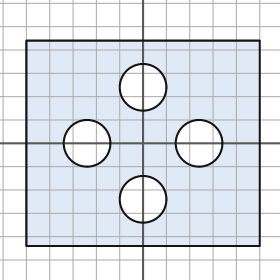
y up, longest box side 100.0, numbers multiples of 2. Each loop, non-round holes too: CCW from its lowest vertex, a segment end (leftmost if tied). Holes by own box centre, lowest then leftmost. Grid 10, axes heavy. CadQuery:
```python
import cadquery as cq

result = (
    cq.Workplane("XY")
    .moveTo(-50.0, -44.0)
    .lineTo(50.0, -44.0)
    .lineTo(50.0, 44.0)
    .lineTo(-50.0, 44.0)
    .close()
    .moveTo(0.0, -24.0)
    .circle(10.0)
    .moveTo(-24.0, 0.0)
    .circle(10.0)
    .moveTo(24.0, 0.0)
    .circle(10.0)
    .moveTo(0.0, 24.0)
    .circle(10.0)
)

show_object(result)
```